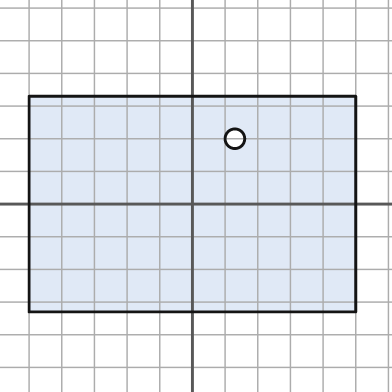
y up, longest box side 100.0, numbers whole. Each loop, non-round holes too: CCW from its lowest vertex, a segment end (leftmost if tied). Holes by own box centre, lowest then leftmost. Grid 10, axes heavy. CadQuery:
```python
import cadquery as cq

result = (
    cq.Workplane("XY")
    .moveTo(-50.0, -33.0)
    .lineTo(50.0, -33.0)
    .lineTo(50.0, 33.0)
    .lineTo(-50.0, 33.0)
    .close()
    .moveTo(13.0, 20.0)
    .circle(3.0)
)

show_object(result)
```